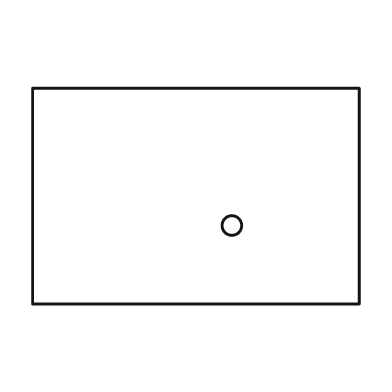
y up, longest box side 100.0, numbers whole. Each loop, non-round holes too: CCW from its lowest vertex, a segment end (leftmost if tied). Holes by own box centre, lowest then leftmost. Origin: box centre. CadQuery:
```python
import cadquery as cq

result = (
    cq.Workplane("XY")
    .moveTo(-50.0, -33.0)
    .lineTo(50.0, -33.0)
    .lineTo(50.0, 33.0)
    .lineTo(-50.0, 33.0)
    .close()
    .moveTo(11.0, -9.0)
    .circle(3.0)
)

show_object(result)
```